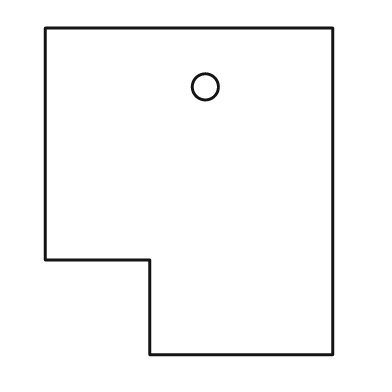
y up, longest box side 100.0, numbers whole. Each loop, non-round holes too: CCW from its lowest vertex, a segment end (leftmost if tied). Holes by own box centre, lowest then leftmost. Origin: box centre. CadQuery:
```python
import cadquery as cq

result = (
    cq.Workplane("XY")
    .moveTo(-12.0, -50.0)
    .lineTo(44.0, -50.0)
    .lineTo(44.0, 50.0)
    .lineTo(-44.0, 50.0)
    .lineTo(-44.0, -21.0)
    .lineTo(-12.0, -21.0)
    .close()
    .moveTo(5.0, 32.0)
    .circle(4.0)
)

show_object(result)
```